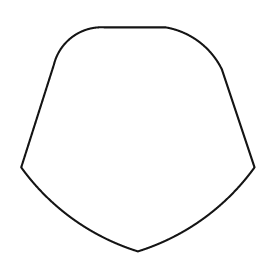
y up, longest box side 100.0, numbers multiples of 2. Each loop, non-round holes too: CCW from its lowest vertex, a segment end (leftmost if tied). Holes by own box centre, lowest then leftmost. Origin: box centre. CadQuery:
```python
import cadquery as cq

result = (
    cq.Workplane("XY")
    .moveTo(0.0, -48.0)
    .threePointArc((28.0, -34.0), (50.0, -12.0))
    .lineTo(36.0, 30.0)
    .threePointArc((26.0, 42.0), (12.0, 48.0))
    .lineTo(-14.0, 48.0)
    .threePointArc((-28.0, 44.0), (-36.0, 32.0))
    .lineTo(-50.0, -12.0)
    .threePointArc((-28.0, -34.0), (0.0, -48.0))
    .close()
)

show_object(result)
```